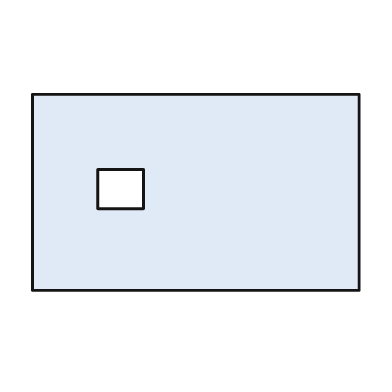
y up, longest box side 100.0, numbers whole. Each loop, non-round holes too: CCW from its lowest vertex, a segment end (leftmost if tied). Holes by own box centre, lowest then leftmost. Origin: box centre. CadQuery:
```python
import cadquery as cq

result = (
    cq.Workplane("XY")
    .moveTo(-50.0, -30.0)
    .lineTo(50.0, -30.0)
    .lineTo(50.0, 30.0)
    .lineTo(-50.0, 30.0)
    .close()
    .moveTo(-30.0, -5.0)
    .lineTo(-16.0, -5.0)
    .lineTo(-16.0, 7.0)
    .lineTo(-30.0, 7.0)
    .close()
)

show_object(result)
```